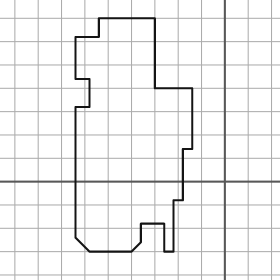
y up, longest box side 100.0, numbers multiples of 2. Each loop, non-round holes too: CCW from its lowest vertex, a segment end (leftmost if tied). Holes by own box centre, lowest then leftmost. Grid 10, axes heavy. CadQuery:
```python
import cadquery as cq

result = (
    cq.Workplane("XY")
    .moveTo(-58.0, -30.0)
    .lineTo(-40.0, -30.0)
    .lineTo(-36.0, -26.0)
    .lineTo(-36.0, -18.0)
    .lineTo(-26.0, -18.0)
    .lineTo(-26.0, -30.0)
    .lineTo(-22.0, -30.0)
    .lineTo(-22.0, -8.0)
    .lineTo(-18.0, -8.0)
    .lineTo(-18.0, 14.0)
    .lineTo(-14.0, 14.0)
    .lineTo(-14.0, 40.0)
    .lineTo(-30.0, 40.0)
    .lineTo(-30.0, 70.0)
    .lineTo(-54.0, 70.0)
    .lineTo(-54.0, 62.0)
    .lineTo(-64.0, 62.0)
    .lineTo(-64.0, 44.0)
    .lineTo(-58.0, 44.0)
    .lineTo(-58.0, 32.0)
    .lineTo(-64.0, 32.0)
    .lineTo(-64.0, -24.0)
    .close()
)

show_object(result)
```